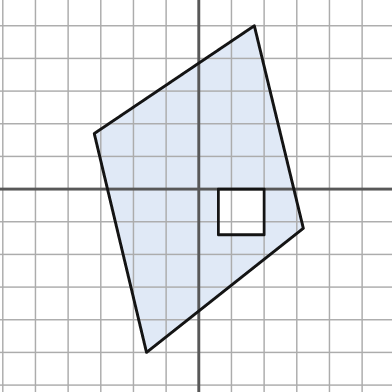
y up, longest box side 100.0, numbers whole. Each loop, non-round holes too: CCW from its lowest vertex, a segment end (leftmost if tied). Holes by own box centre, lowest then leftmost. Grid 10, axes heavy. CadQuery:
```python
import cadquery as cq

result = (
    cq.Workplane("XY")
    .moveTo(-16.0, -50.0)
    .lineTo(32.0, -12.0)
    .lineTo(17.0, 50.0)
    .lineTo(-32.0, 17.0)
    .close()
    .moveTo(6.0, -14.0)
    .lineTo(20.0, -14.0)
    .lineTo(20.0, 0.0)
    .lineTo(6.0, 0.0)
    .close()
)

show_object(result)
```